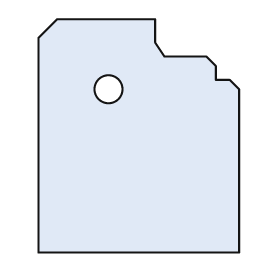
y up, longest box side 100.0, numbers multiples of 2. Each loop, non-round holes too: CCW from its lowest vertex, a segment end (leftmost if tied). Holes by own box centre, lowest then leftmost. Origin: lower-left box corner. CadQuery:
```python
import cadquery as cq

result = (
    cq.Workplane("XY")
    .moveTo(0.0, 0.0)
    .lineTo(86.0, 0.0)
    .lineTo(86.0, 70.0)
    .lineTo(82.0, 74.0)
    .lineTo(76.0, 74.0)
    .lineTo(76.0, 80.0)
    .lineTo(72.0, 84.0)
    .lineTo(54.0, 84.0)
    .lineTo(50.0, 90.0)
    .lineTo(50.0, 100.0)
    .lineTo(8.0, 100.0)
    .lineTo(0.0, 92.0)
    .close()
    .moveTo(30.0, 70.0)
    .circle(6.0)
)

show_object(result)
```